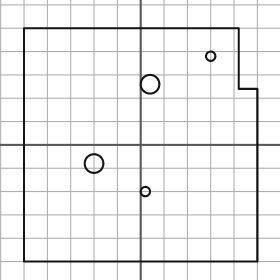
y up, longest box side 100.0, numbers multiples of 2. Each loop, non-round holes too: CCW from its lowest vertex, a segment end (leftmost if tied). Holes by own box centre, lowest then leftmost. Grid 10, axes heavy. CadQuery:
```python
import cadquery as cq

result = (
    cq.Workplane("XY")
    .moveTo(-50.0, -50.0)
    .lineTo(50.0, -50.0)
    .lineTo(50.0, 24.0)
    .lineTo(42.0, 24.0)
    .lineTo(42.0, 50.0)
    .lineTo(-50.0, 50.0)
    .close()
    .moveTo(2.0, -20.0)
    .circle(2.0)
    .moveTo(-20.0, -8.0)
    .circle(4.0)
    .moveTo(4.0, 26.0)
    .circle(4.0)
    .moveTo(30.0, 38.0)
    .circle(2.0)
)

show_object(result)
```